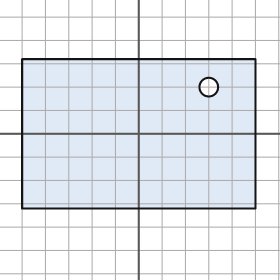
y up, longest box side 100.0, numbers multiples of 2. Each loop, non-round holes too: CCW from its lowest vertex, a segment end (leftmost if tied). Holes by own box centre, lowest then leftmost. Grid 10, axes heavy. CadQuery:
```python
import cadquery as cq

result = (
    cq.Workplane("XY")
    .moveTo(-50.0, -32.0)
    .lineTo(50.0, -32.0)
    .lineTo(50.0, 32.0)
    .lineTo(-50.0, 32.0)
    .close()
    .moveTo(30.0, 20.0)
    .circle(4.0)
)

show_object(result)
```